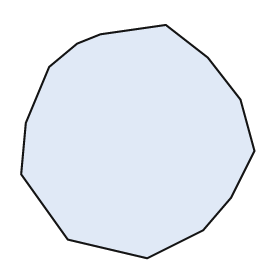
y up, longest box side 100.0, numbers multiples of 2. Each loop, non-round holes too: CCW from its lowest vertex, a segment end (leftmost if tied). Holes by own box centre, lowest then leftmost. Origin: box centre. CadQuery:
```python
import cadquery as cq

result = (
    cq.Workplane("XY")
    .moveTo(4.0, -50.0)
    .lineTo(28.0, -38.0)
    .lineTo(40.0, -24.0)
    .lineTo(50.0, -4.0)
    .lineTo(44.0, 18.0)
    .lineTo(30.0, 36.0)
    .lineTo(12.0, 50.0)
    .lineTo(-16.0, 46.0)
    .lineTo(-26.0, 42.0)
    .lineTo(-38.0, 32.0)
    .lineTo(-48.0, 8.0)
    .lineTo(-50.0, -14.0)
    .lineTo(-30.0, -42.0)
    .close()
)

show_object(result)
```